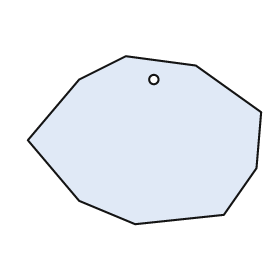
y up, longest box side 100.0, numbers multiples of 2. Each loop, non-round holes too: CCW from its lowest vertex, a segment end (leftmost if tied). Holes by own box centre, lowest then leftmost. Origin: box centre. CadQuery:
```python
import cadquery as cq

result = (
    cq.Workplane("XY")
    .moveTo(-4.0, -36.0)
    .lineTo(34.0, -32.0)
    .lineTo(48.0, -12.0)
    .lineTo(50.0, 12.0)
    .lineTo(22.0, 32.0)
    .lineTo(-8.0, 36.0)
    .lineTo(-28.0, 26.0)
    .lineTo(-50.0, 0.0)
    .lineTo(-28.0, -26.0)
    .close()
    .moveTo(4.0, 26.0)
    .circle(2.0)
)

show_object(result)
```